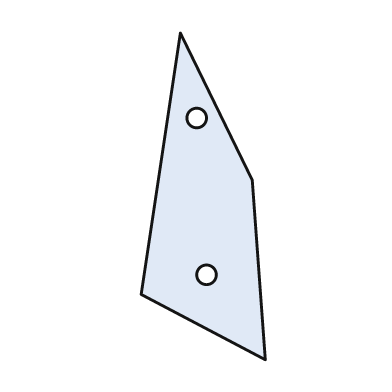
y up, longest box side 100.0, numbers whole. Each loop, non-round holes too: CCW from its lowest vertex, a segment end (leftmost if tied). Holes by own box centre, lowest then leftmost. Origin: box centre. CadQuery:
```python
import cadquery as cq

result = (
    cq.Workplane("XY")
    .moveTo(19.0, -50.0)
    .lineTo(15.0, 5.0)
    .lineTo(-7.0, 50.0)
    .lineTo(-19.0, -30.0)
    .close()
    .moveTo(1.0, -24.0)
    .circle(3.0)
    .moveTo(-2.0, 24.0)
    .circle(3.0)
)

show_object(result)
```